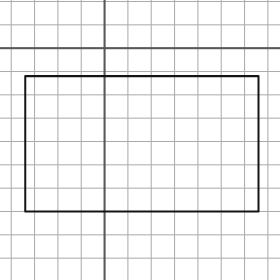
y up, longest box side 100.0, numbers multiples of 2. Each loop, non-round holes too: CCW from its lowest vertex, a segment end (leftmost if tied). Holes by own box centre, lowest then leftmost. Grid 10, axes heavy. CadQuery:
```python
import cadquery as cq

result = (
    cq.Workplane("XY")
    .moveTo(-34.0, -70.0)
    .lineTo(66.0, -70.0)
    .lineTo(66.0, -12.0)
    .lineTo(-34.0, -12.0)
    .close()
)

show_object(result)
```